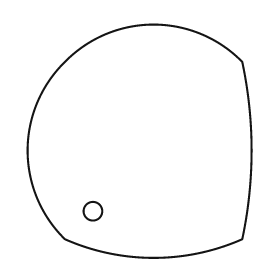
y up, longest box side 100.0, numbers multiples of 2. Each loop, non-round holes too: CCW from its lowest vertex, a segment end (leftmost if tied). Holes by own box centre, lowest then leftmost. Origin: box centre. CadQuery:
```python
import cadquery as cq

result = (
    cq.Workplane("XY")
    .moveTo(-32.0, -42.0)
    .threePointArc((6.0, -50.0), (44.0, -42.0))
    .threePointArc((48.0, -4.0), (44.0, 34.0))
    .threePointArc((6.0, 50.0), (-32.0, 34.0))
    .threePointArc((-48.0, -4.0), (-32.0, -42.0))
    .close()
    .moveTo(-20.0, -30.0)
    .circle(4.0)
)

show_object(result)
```